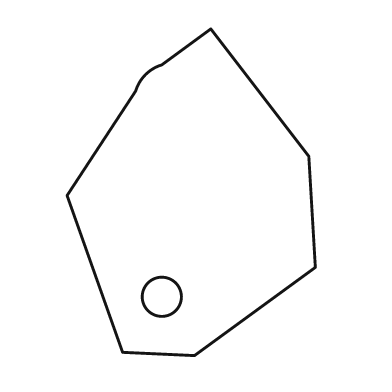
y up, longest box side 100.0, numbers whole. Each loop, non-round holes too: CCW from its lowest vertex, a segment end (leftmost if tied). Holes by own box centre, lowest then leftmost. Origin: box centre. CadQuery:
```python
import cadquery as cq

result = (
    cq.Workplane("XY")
    .moveTo(1.0, -50.0)
    .lineTo(38.0, -23.0)
    .lineTo(36.0, 11.0)
    .lineTo(6.0, 50.0)
    .lineTo(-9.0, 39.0)
    .threePointArc((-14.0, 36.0), (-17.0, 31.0))
    .lineTo(-38.0, -1.0)
    .lineTo(-21.0, -49.0)
    .close()
    .moveTo(-9.0, -32.0)
    .circle(6.0)
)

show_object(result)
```